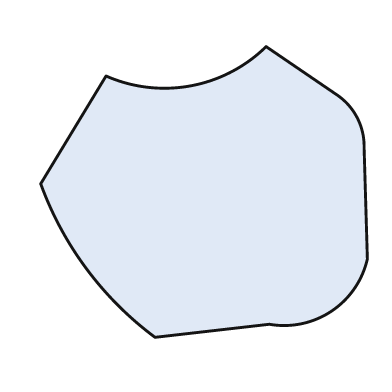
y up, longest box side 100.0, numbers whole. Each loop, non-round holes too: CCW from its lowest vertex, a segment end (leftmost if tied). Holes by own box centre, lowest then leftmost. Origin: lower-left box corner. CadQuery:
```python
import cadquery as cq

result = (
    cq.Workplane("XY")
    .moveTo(35.0, 0.0)
    .lineTo(70.0, 4.0)
    .threePointArc((89.0, 8.0), (100.0, 24.0))
    .lineTo(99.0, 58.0)
    .threePointArc((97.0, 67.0), (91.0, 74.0))
    .lineTo(69.0, 89.0)
    .threePointArc((46.0, 77.0), (20.0, 80.0))
    .lineTo(0.0, 47.0)
    .threePointArc((14.0, 21.0), (35.0, 0.0))
    .close()
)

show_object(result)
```